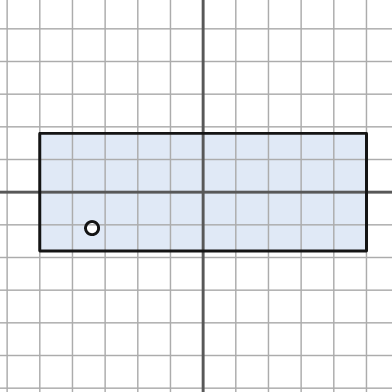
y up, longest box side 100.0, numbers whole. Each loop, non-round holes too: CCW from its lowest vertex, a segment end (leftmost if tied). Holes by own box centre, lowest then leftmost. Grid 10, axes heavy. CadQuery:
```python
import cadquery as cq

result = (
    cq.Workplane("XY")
    .moveTo(-50.0, -18.0)
    .lineTo(50.0, -18.0)
    .lineTo(50.0, 18.0)
    .lineTo(-50.0, 18.0)
    .close()
    .moveTo(-34.0, -11.0)
    .circle(2.0)
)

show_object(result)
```